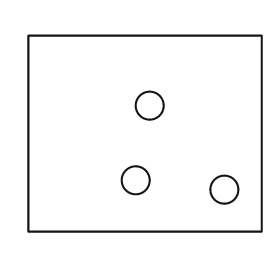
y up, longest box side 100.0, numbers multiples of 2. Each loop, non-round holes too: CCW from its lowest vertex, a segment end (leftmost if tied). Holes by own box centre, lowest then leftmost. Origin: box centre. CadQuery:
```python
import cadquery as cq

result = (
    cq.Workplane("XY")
    .moveTo(-50.0, -42.0)
    .lineTo(50.0, -42.0)
    .lineTo(50.0, 42.0)
    .lineTo(-50.0, 42.0)
    .close()
    .moveTo(34.0, -24.0)
    .circle(6.0)
    .moveTo(-4.0, -20.0)
    .circle(6.0)
    .moveTo(2.0, 12.0)
    .circle(6.0)
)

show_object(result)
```